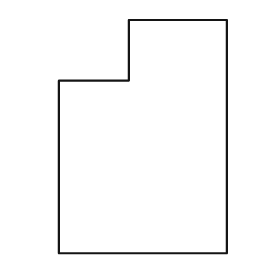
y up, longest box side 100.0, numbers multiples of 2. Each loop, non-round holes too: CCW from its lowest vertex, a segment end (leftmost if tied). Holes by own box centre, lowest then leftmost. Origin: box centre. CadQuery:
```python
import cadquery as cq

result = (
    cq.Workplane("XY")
    .moveTo(-36.0, -50.0)
    .lineTo(36.0, -50.0)
    .lineTo(36.0, 50.0)
    .lineTo(-6.0, 50.0)
    .lineTo(-6.0, 24.0)
    .lineTo(-36.0, 24.0)
    .close()
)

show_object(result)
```